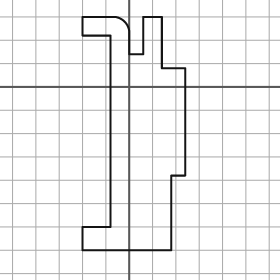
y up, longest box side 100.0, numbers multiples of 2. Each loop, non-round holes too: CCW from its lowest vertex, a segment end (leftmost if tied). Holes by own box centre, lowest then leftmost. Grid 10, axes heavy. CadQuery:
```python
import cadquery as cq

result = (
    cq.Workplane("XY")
    .moveTo(-20.0, -70.0)
    .lineTo(18.0, -70.0)
    .lineTo(18.0, -38.0)
    .lineTo(24.0, -38.0)
    .lineTo(24.0, 8.0)
    .lineTo(14.0, 8.0)
    .lineTo(14.0, 30.0)
    .lineTo(6.0, 30.0)
    .lineTo(6.0, 14.0)
    .lineTo(0.0, 14.0)
    .lineTo(0.0, 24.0)
    .threePointArc((-2.0, 28.0), (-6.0, 30.0))
    .lineTo(-20.0, 30.0)
    .lineTo(-20.0, 22.0)
    .lineTo(-8.0, 22.0)
    .lineTo(-8.0, -60.0)
    .lineTo(-20.0, -60.0)
    .close()
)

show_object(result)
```